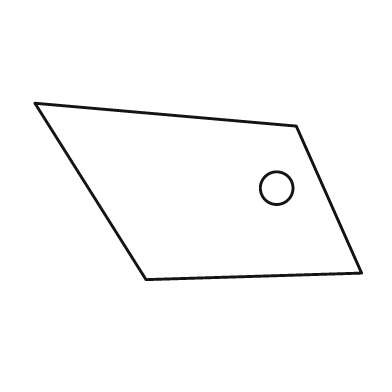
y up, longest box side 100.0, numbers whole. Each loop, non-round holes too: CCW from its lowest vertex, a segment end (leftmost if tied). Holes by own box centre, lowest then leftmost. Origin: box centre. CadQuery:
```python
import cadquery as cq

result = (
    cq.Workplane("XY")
    .moveTo(-16.0, -27.0)
    .lineTo(50.0, -25.0)
    .lineTo(30.0, 20.0)
    .lineTo(-50.0, 27.0)
    .close()
    .moveTo(24.0, 1.0)
    .circle(5.0)
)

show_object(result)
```